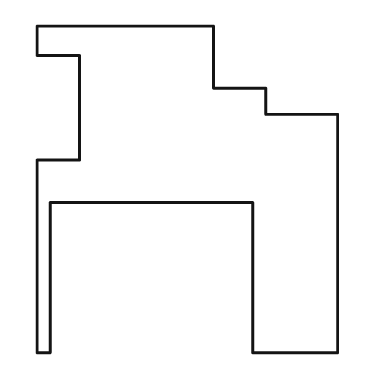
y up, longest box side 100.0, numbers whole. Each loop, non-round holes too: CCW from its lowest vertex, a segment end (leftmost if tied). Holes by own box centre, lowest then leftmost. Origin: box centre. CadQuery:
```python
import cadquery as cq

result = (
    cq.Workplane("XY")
    .moveTo(-46.0, -50.0)
    .lineTo(-42.0, -50.0)
    .lineTo(-42.0, -4.0)
    .lineTo(20.0, -4.0)
    .lineTo(20.0, -50.0)
    .lineTo(46.0, -50.0)
    .lineTo(46.0, 23.0)
    .lineTo(24.0, 23.0)
    .lineTo(24.0, 31.0)
    .lineTo(8.0, 31.0)
    .lineTo(8.0, 50.0)
    .lineTo(-46.0, 50.0)
    .lineTo(-46.0, 41.0)
    .lineTo(-33.0, 41.0)
    .lineTo(-33.0, 9.0)
    .lineTo(-46.0, 9.0)
    .close()
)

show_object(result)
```